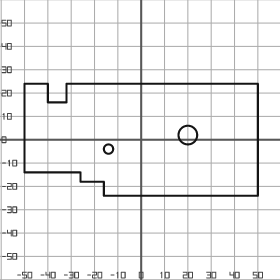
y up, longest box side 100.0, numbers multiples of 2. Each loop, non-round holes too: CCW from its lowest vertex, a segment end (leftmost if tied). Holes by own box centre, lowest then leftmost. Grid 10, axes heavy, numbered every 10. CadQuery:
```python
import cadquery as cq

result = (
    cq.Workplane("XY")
    .moveTo(-16.0, -24.0)
    .lineTo(50.0, -24.0)
    .lineTo(50.0, 24.0)
    .lineTo(-32.0, 24.0)
    .lineTo(-32.0, 16.0)
    .lineTo(-40.0, 16.0)
    .lineTo(-40.0, 24.0)
    .lineTo(-50.0, 24.0)
    .lineTo(-50.0, -14.0)
    .lineTo(-26.0, -14.0)
    .lineTo(-26.0, -18.0)
    .lineTo(-16.0, -18.0)
    .close()
    .moveTo(-14.0, -4.0)
    .circle(2.0)
    .moveTo(20.0, 2.0)
    .circle(4.0)
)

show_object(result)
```